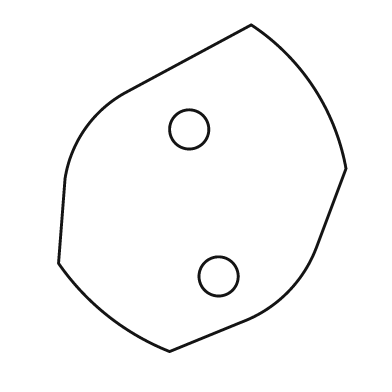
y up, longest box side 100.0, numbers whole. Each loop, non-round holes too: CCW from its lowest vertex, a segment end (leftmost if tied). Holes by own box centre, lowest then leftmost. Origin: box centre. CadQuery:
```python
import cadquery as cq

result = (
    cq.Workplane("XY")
    .moveTo(-10.0, -50.0)
    .lineTo(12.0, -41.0)
    .threePointArc((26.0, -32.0), (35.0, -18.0))
    .lineTo(44.0, 6.0)
    .threePointArc((34.0, 31.0), (15.0, 50.0))
    .lineTo(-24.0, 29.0)
    .threePointArc((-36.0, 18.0), (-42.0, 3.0))
    .lineTo(-44.0, -23.0)
    .threePointArc((-29.0, -39.0), (-10.0, -50.0))
    .close()
    .moveTo(5.0, -27.0)
    .circle(6.0)
    .moveTo(-4.0, 18.0)
    .circle(6.0)
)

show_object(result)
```